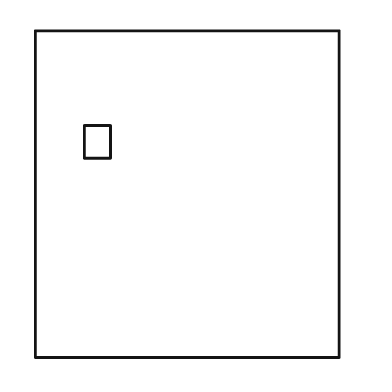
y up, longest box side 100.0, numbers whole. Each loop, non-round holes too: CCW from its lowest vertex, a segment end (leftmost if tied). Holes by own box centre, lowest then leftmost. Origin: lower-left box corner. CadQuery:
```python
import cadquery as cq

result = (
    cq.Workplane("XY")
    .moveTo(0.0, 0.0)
    .lineTo(93.0, 0.0)
    .lineTo(93.0, 100.0)
    .lineTo(0.0, 100.0)
    .close()
    .moveTo(15.0, 61.0)
    .lineTo(23.0, 61.0)
    .lineTo(23.0, 71.0)
    .lineTo(15.0, 71.0)
    .close()
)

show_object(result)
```